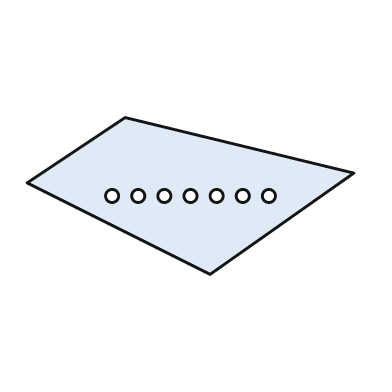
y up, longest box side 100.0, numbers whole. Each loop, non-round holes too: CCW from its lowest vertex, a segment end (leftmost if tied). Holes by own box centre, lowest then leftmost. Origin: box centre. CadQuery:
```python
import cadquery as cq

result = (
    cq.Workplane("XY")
    .moveTo(6.0, -24.0)
    .lineTo(50.0, 7.0)
    .lineTo(-20.0, 24.0)
    .lineTo(-50.0, 4.0)
    .close()
    .moveTo(-24.0, 0.0)
    .circle(2.0)
    .moveTo(-16.0, 0.0)
    .circle(2.0)
    .moveTo(-8.0, 0.0)
    .circle(2.0)
    .moveTo(0.0, 0.0)
    .circle(2.0)
    .moveTo(8.0, 0.0)
    .circle(2.0)
    .moveTo(16.0, 0.0)
    .circle(2.0)
    .moveTo(24.0, 0.0)
    .circle(2.0)
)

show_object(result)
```